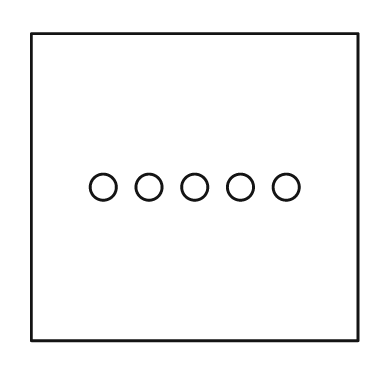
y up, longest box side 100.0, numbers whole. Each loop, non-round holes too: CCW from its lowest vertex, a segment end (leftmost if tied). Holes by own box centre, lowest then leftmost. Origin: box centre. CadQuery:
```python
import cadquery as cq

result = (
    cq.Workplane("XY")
    .moveTo(-50.0, -47.0)
    .lineTo(50.0, -47.0)
    .lineTo(50.0, 47.0)
    .lineTo(-50.0, 47.0)
    .close()
    .moveTo(-28.0, 0.0)
    .circle(4.0)
    .moveTo(-14.0, 0.0)
    .circle(4.0)
    .moveTo(0.0, 0.0)
    .circle(4.0)
    .moveTo(14.0, 0.0)
    .circle(4.0)
    .moveTo(28.0, 0.0)
    .circle(4.0)
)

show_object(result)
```